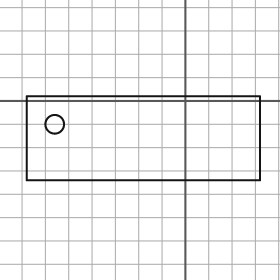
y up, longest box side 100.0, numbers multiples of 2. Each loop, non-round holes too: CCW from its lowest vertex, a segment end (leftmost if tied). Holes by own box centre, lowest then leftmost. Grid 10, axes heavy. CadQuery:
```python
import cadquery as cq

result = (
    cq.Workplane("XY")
    .moveTo(-68.0, -34.0)
    .lineTo(32.0, -34.0)
    .lineTo(32.0, 2.0)
    .lineTo(-68.0, 2.0)
    .close()
    .moveTo(-56.0, -10.0)
    .circle(4.0)
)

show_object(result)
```